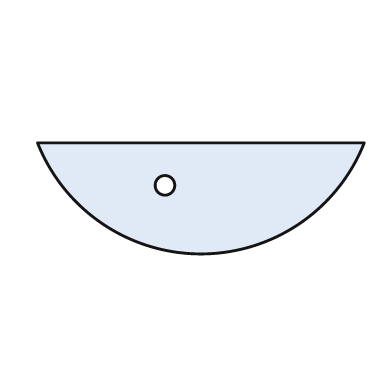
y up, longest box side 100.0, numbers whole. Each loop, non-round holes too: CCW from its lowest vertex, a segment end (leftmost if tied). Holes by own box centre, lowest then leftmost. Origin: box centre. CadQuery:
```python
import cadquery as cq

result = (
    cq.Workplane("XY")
    .moveTo(-50.0, 17.0)
    .threePointArc((0.0, -17.0), (50.0, 17.0))
    .close()
    .moveTo(-11.0, 4.0)
    .circle(3.0)
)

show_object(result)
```